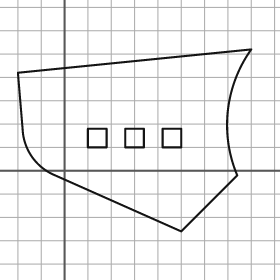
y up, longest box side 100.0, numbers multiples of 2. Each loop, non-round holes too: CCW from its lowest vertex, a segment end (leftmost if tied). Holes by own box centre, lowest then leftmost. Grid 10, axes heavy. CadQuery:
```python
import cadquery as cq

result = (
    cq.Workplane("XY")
    .moveTo(50.0, -26.0)
    .lineTo(74.0, -2.0)
    .threePointArc((70.0, 26.0), (80.0, 52.0))
    .lineTo(-20.0, 42.0)
    .lineTo(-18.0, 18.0)
    .threePointArc((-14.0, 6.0), (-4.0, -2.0))
    .close()
    .moveTo(10.0, 10.0)
    .lineTo(18.0, 10.0)
    .lineTo(18.0, 18.0)
    .lineTo(10.0, 18.0)
    .close()
    .moveTo(26.0, 10.0)
    .lineTo(34.0, 10.0)
    .lineTo(34.0, 18.0)
    .lineTo(26.0, 18.0)
    .close()
    .moveTo(42.0, 10.0)
    .lineTo(50.0, 10.0)
    .lineTo(50.0, 18.0)
    .lineTo(42.0, 18.0)
    .close()
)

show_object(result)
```